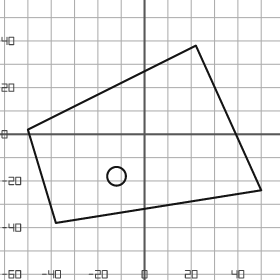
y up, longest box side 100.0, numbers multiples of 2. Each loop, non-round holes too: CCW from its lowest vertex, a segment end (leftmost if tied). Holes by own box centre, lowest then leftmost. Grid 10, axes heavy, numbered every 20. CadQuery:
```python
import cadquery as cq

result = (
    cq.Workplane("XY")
    .moveTo(-38.0, -38.0)
    .lineTo(50.0, -24.0)
    .lineTo(22.0, 38.0)
    .lineTo(-50.0, 2.0)
    .close()
    .moveTo(-12.0, -18.0)
    .circle(4.0)
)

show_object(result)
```